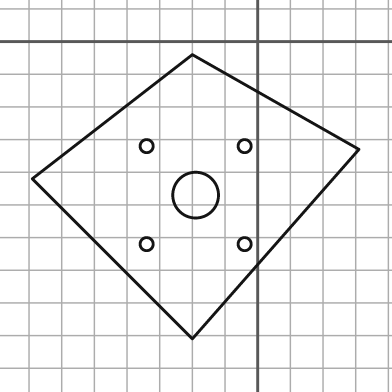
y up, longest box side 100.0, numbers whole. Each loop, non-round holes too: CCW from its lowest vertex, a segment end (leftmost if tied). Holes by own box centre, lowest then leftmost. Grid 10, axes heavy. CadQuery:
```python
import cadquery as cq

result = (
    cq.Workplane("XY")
    .moveTo(-20.0, -91.0)
    .lineTo(31.0, -33.0)
    .lineTo(-20.0, -4.0)
    .lineTo(-69.0, -42.0)
    .close()
    .moveTo(-34.0, -62.0)
    .circle(2.0)
    .moveTo(-4.0, -62.0)
    .circle(2.0)
    .moveTo(-19.0, -47.0)
    .circle(7.0)
    .moveTo(-34.0, -32.0)
    .circle(2.0)
    .moveTo(-4.0, -32.0)
    .circle(2.0)
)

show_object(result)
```